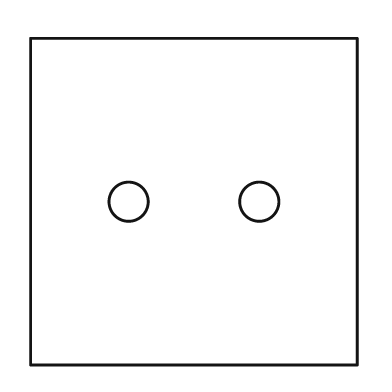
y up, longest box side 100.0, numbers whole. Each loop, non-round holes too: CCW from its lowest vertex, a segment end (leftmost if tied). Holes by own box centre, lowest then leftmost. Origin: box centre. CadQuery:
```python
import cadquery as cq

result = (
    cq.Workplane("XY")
    .moveTo(-50.0, -50.0)
    .lineTo(50.0, -50.0)
    .lineTo(50.0, 50.0)
    .lineTo(-50.0, 50.0)
    .close()
    .moveTo(-20.0, 0.0)
    .circle(6.0)
    .moveTo(20.0, 0.0)
    .circle(6.0)
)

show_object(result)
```